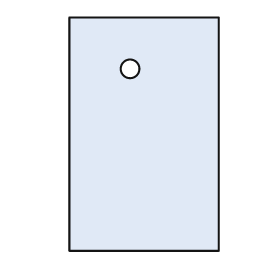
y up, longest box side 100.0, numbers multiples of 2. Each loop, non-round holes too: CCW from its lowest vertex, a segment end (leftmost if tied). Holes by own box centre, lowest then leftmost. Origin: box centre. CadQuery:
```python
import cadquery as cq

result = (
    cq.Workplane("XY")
    .moveTo(-32.0, -50.0)
    .lineTo(32.0, -50.0)
    .lineTo(32.0, 50.0)
    .lineTo(-32.0, 50.0)
    .close()
    .moveTo(-6.0, 28.0)
    .circle(4.0)
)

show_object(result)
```